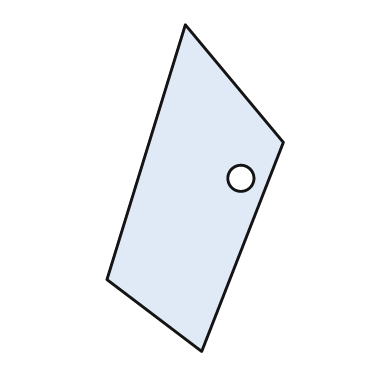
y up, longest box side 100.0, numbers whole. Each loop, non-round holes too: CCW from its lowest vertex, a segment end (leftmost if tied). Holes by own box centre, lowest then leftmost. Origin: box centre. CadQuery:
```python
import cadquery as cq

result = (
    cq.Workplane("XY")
    .moveTo(2.0, -50.0)
    .lineTo(27.0, 14.0)
    .lineTo(-3.0, 50.0)
    .lineTo(-27.0, -28.0)
    .close()
    .moveTo(14.0, 3.0)
    .circle(4.0)
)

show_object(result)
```